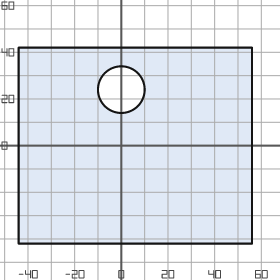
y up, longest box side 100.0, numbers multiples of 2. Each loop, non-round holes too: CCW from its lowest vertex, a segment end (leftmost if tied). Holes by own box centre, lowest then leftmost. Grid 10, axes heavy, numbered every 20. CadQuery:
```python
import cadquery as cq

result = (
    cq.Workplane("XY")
    .moveTo(-44.0, -42.0)
    .lineTo(56.0, -42.0)
    .lineTo(56.0, 42.0)
    .lineTo(-44.0, 42.0)
    .close()
    .moveTo(0.0, 24.0)
    .circle(10.0)
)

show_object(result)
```